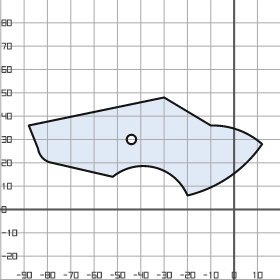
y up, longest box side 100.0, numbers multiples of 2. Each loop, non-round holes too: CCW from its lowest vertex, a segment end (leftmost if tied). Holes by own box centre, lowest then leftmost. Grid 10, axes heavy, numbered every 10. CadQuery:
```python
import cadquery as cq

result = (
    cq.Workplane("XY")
    .moveTo(-20.0, 6.0)
    .threePointArc((-2.0, 14.0), (12.0, 28.0))
    .threePointArc((2.0, 34.0), (-10.0, 36.0))
    .lineTo(-30.0, 48.0)
    .lineTo(-88.0, 36.0)
    .lineTo(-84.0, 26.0)
    .threePointArc((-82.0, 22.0), (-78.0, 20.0))
    .lineTo(-52.0, 14.0)
    .threePointArc((-34.0, 18.0), (-20.0, 6.0))
    .close()
    .moveTo(-44.0, 30.0)
    .circle(2.0)
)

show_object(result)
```